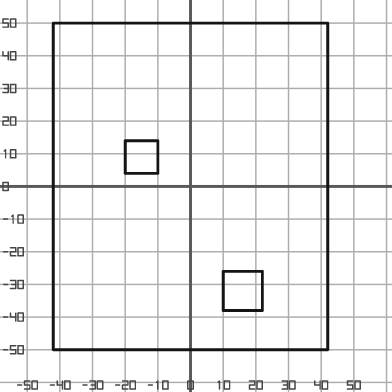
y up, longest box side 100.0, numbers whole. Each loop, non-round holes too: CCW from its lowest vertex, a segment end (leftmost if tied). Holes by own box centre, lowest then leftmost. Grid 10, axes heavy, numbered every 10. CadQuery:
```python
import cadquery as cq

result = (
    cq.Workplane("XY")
    .moveTo(-42.0, -50.0)
    .lineTo(42.0, -50.0)
    .lineTo(42.0, 50.0)
    .lineTo(-42.0, 50.0)
    .close()
    .moveTo(10.0, -38.0)
    .lineTo(22.0, -38.0)
    .lineTo(22.0, -26.0)
    .lineTo(10.0, -26.0)
    .close()
    .moveTo(-20.0, 4.0)
    .lineTo(-10.0, 4.0)
    .lineTo(-10.0, 14.0)
    .lineTo(-20.0, 14.0)
    .close()
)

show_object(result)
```